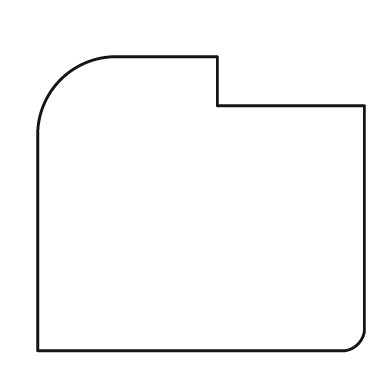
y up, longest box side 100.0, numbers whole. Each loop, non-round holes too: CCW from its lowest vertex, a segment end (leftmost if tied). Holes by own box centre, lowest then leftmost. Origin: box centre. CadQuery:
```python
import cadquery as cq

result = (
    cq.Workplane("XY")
    .moveTo(-50.0, -45.0)
    .lineTo(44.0, -45.0)
    .threePointArc((48.0, -43.0), (50.0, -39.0))
    .lineTo(50.0, 30.0)
    .lineTo(5.0, 30.0)
    .lineTo(5.0, 45.0)
    .lineTo(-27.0, 45.0)
    .threePointArc((-43.0, 38.0), (-50.0, 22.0))
    .close()
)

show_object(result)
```